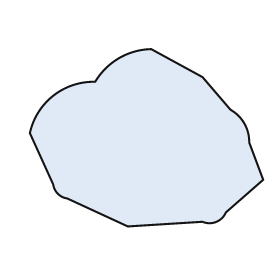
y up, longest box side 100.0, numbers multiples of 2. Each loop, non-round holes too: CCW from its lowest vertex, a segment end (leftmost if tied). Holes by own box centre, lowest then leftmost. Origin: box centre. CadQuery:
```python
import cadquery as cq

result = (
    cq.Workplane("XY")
    .moveTo(-8.0, -38.0)
    .lineTo(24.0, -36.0)
    .threePointArc((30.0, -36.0), (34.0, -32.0))
    .lineTo(50.0, -18.0)
    .lineTo(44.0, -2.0)
    .threePointArc((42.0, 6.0), (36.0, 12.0))
    .lineTo(24.0, 26.0)
    .lineTo(2.0, 38.0)
    .threePointArc((-12.0, 34.0), (-22.0, 24.0))
    .threePointArc((-40.0, 18.0), (-50.0, 2.0))
    .lineTo(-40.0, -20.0)
    .threePointArc((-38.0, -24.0), (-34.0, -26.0))
    .close()
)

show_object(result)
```